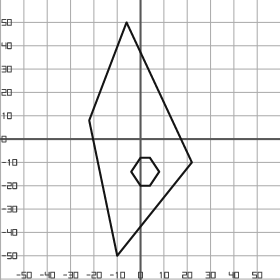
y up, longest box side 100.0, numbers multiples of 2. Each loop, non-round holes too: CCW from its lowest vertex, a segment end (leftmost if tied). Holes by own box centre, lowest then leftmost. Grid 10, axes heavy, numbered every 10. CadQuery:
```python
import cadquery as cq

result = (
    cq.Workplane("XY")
    .moveTo(-10.0, -50.0)
    .lineTo(22.0, -10.0)
    .lineTo(-6.0, 50.0)
    .lineTo(-22.0, 8.0)
    .close()
    .moveTo(0.0, -20.0)
    .lineTo(4.0, -20.0)
    .lineTo(8.0, -14.0)
    .lineTo(4.0, -8.0)
    .lineTo(0.0, -8.0)
    .lineTo(-4.0, -14.0)
    .close()
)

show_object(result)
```